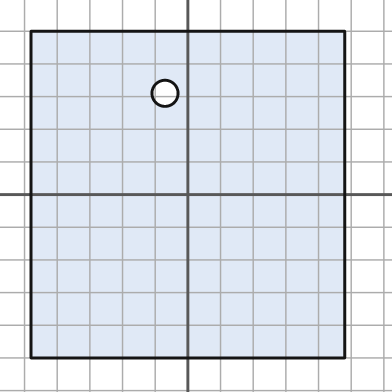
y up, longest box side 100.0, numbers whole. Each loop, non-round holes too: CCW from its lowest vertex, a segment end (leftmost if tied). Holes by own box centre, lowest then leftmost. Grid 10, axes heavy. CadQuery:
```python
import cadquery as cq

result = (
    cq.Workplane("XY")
    .moveTo(-48.0, -50.0)
    .lineTo(48.0, -50.0)
    .lineTo(48.0, 50.0)
    .lineTo(-48.0, 50.0)
    .close()
    .moveTo(-7.0, 31.0)
    .circle(4.0)
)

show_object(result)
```